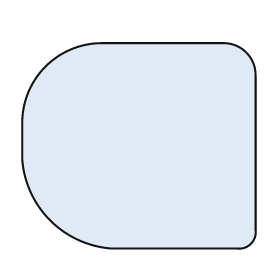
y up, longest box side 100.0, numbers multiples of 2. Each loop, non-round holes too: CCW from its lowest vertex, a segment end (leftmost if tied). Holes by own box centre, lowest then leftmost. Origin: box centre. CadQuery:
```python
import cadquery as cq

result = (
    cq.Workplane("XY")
    .moveTo(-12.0, -44.0)
    .lineTo(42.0, -44.0)
    .threePointArc((48.0, -42.0), (50.0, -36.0))
    .lineTo(50.0, 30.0)
    .threePointArc((46.0, 40.0), (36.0, 44.0))
    .lineTo(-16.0, 44.0)
    .threePointArc((-40.0, 34.0), (-50.0, 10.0))
    .lineTo(-50.0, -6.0)
    .threePointArc((-38.0, -32.0), (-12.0, -44.0))
    .close()
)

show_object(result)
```